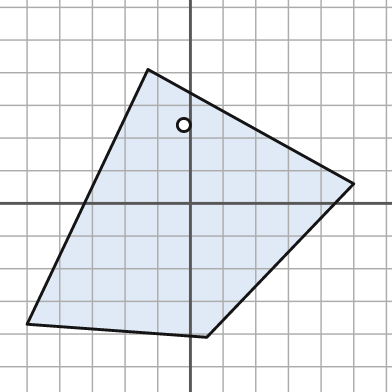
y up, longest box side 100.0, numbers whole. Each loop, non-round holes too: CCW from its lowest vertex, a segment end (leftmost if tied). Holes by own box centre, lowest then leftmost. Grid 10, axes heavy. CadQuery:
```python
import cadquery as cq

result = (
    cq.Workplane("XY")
    .moveTo(5.0, -41.0)
    .lineTo(50.0, 6.0)
    .lineTo(-13.0, 41.0)
    .lineTo(-50.0, -37.0)
    .close()
    .moveTo(-2.0, 24.0)
    .circle(2.0)
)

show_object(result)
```